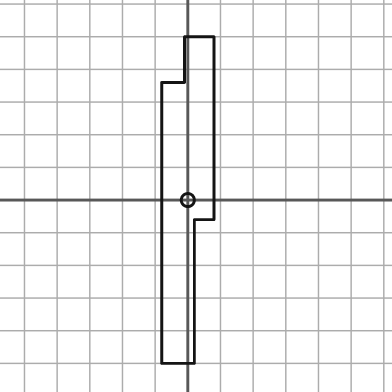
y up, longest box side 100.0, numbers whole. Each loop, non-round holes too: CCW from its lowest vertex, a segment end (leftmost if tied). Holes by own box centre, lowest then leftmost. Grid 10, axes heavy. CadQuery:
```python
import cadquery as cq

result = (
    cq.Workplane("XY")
    .moveTo(-8.0, -50.0)
    .lineTo(2.0, -50.0)
    .lineTo(2.0, -6.0)
    .lineTo(8.0, -6.0)
    .lineTo(8.0, 50.0)
    .lineTo(-1.0, 50.0)
    .lineTo(-1.0, 36.0)
    .lineTo(-8.0, 36.0)
    .close()
    .moveTo(0.0, 0.0)
    .circle(2.0)
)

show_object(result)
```